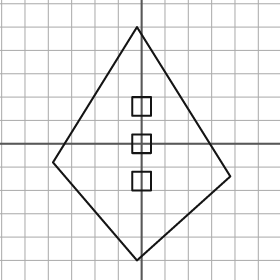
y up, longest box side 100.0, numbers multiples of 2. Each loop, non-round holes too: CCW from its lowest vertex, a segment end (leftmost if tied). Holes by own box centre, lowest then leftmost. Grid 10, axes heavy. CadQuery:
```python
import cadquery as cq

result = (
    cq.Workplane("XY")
    .moveTo(-2.0, -50.0)
    .lineTo(38.0, -14.0)
    .lineTo(-2.0, 50.0)
    .lineTo(-38.0, -8.0)
    .close()
    .moveTo(-4.0, -20.0)
    .lineTo(4.0, -20.0)
    .lineTo(4.0, -12.0)
    .lineTo(-4.0, -12.0)
    .close()
    .moveTo(-4.0, -4.0)
    .lineTo(4.0, -4.0)
    .lineTo(4.0, 4.0)
    .lineTo(-4.0, 4.0)
    .close()
    .moveTo(-4.0, 12.0)
    .lineTo(4.0, 12.0)
    .lineTo(4.0, 20.0)
    .lineTo(-4.0, 20.0)
    .close()
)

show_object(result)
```